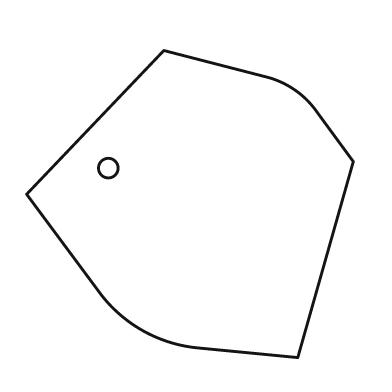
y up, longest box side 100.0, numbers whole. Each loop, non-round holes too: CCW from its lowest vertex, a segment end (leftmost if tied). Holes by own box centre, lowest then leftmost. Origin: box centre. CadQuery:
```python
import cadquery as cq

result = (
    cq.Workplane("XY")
    .moveTo(33.0, -47.0)
    .lineTo(50.0, 13.0)
    .lineTo(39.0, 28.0)
    .threePointArc((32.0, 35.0), (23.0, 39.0))
    .lineTo(-8.0, 47.0)
    .lineTo(-50.0, 3.0)
    .lineTo(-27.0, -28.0)
    .threePointArc((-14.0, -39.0), (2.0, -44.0))
    .close()
    .moveTo(-25.0, 11.0)
    .circle(3.0)
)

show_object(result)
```